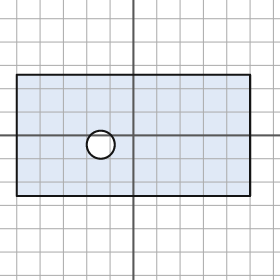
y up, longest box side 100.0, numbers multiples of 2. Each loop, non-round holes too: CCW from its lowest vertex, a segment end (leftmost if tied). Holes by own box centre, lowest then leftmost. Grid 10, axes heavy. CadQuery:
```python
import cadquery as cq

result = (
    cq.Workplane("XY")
    .moveTo(-50.0, -26.0)
    .lineTo(50.0, -26.0)
    .lineTo(50.0, 26.0)
    .lineTo(-50.0, 26.0)
    .close()
    .moveTo(-14.0, -4.0)
    .circle(6.0)
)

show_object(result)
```